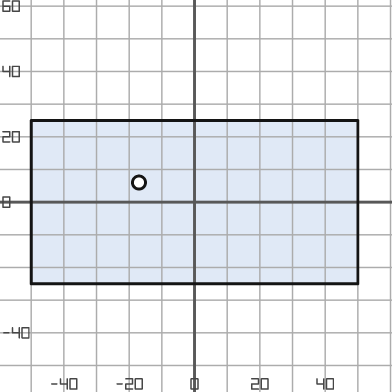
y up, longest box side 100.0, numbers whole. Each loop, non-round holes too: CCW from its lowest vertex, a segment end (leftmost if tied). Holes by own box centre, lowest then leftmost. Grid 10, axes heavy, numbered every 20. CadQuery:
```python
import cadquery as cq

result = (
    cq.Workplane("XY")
    .moveTo(-50.0, -25.0)
    .lineTo(50.0, -25.0)
    .lineTo(50.0, 25.0)
    .lineTo(-50.0, 25.0)
    .close()
    .moveTo(-17.0, 6.0)
    .circle(2.0)
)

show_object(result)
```